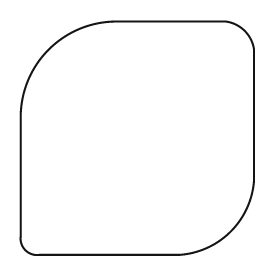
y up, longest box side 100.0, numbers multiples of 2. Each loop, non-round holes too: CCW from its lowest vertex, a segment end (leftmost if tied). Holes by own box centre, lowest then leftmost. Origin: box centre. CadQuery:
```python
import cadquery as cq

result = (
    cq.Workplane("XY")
    .moveTo(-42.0, -50.0)
    .lineTo(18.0, -50.0)
    .threePointArc((40.0, -40.0), (50.0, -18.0))
    .lineTo(50.0, 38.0)
    .threePointArc((46.0, 46.0), (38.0, 50.0))
    .lineTo(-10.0, 50.0)
    .threePointArc((-38.0, 38.0), (-50.0, 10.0))
    .lineTo(-50.0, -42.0)
    .threePointArc((-48.0, -48.0), (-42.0, -50.0))
    .close()
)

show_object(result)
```